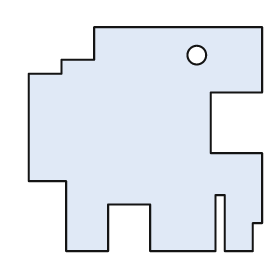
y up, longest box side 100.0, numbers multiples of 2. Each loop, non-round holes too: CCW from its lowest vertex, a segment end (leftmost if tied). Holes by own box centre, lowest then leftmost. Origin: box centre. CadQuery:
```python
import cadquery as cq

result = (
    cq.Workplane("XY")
    .moveTo(-34.0, -48.0)
    .lineTo(-16.0, -48.0)
    .lineTo(-16.0, -28.0)
    .lineTo(2.0, -28.0)
    .lineTo(2.0, -48.0)
    .lineTo(30.0, -48.0)
    .lineTo(30.0, -24.0)
    .lineTo(34.0, -24.0)
    .lineTo(34.0, -48.0)
    .lineTo(46.0, -48.0)
    .lineTo(46.0, -36.0)
    .lineTo(50.0, -36.0)
    .lineTo(50.0, -6.0)
    .lineTo(28.0, -6.0)
    .lineTo(28.0, 20.0)
    .lineTo(50.0, 20.0)
    .lineTo(50.0, 48.0)
    .lineTo(-22.0, 48.0)
    .lineTo(-22.0, 34.0)
    .lineTo(-36.0, 34.0)
    .lineTo(-36.0, 28.0)
    .lineTo(-50.0, 28.0)
    .lineTo(-50.0, -18.0)
    .lineTo(-34.0, -18.0)
    .close()
    .moveTo(22.0, 36.0)
    .circle(4.0)
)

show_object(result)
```